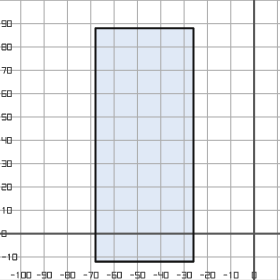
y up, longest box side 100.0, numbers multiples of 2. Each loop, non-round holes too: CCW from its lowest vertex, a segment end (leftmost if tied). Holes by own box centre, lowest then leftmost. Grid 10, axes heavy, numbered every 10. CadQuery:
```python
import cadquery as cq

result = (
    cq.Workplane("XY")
    .moveTo(-68.0, -12.0)
    .lineTo(-26.0, -12.0)
    .lineTo(-26.0, 88.0)
    .lineTo(-68.0, 88.0)
    .close()
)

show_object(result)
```